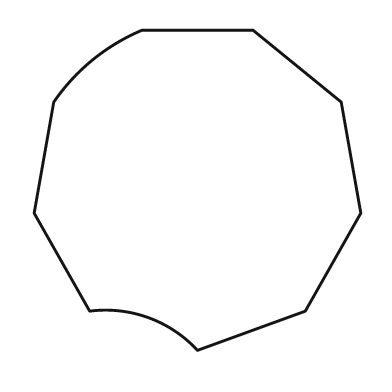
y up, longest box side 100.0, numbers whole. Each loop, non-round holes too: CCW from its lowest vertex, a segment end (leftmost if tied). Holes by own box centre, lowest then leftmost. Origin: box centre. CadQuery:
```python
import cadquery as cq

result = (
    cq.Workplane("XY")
    .moveTo(0.0, -49.0)
    .lineTo(33.0, -37.0)
    .lineTo(50.0, -7.0)
    .lineTo(44.0, 27.0)
    .lineTo(17.0, 49.0)
    .lineTo(-17.0, 49.0)
    .threePointArc((-32.0, 40.0), (-44.0, 27.0))
    .lineTo(-50.0, -7.0)
    .lineTo(-33.0, -37.0)
    .threePointArc((-15.0, -39.0), (0.0, -49.0))
    .close()
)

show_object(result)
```